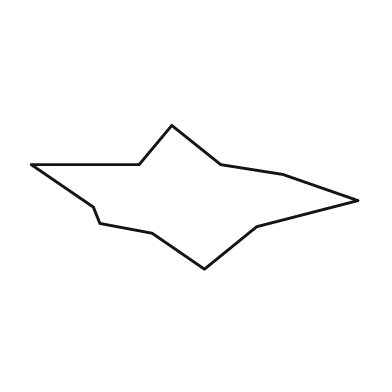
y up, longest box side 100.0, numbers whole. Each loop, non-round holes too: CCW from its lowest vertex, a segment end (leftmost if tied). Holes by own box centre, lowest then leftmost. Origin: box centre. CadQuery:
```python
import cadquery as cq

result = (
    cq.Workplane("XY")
    .moveTo(3.0, -22.0)
    .lineTo(19.0, -9.0)
    .lineTo(50.0, -1.0)
    .lineTo(27.0, 7.0)
    .lineTo(8.0, 10.0)
    .lineTo(-7.0, 22.0)
    .lineTo(-17.0, 10.0)
    .lineTo(-50.0, 10.0)
    .lineTo(-31.0, -3.0)
    .lineTo(-29.0, -8.0)
    .lineTo(-13.0, -11.0)
    .close()
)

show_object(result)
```